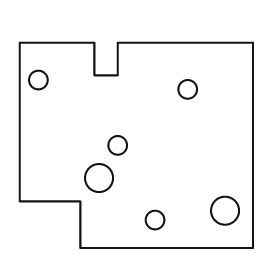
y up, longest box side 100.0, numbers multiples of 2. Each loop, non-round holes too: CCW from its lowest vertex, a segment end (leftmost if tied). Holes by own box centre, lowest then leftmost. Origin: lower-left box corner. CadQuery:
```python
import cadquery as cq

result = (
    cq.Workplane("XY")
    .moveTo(26.0, 0.0)
    .lineTo(100.0, 0.0)
    .lineTo(100.0, 88.0)
    .lineTo(42.0, 88.0)
    .lineTo(42.0, 74.0)
    .lineTo(32.0, 74.0)
    .lineTo(32.0, 88.0)
    .lineTo(0.0, 88.0)
    .lineTo(0.0, 20.0)
    .lineTo(26.0, 20.0)
    .close()
    .moveTo(58.0, 12.0)
    .circle(4.0)
    .moveTo(88.0, 16.0)
    .circle(6.0)
    .moveTo(34.0, 30.0)
    .circle(6.0)
    .moveTo(42.0, 44.0)
    .circle(4.0)
    .moveTo(72.0, 68.0)
    .circle(4.0)
    .moveTo(8.0, 72.0)
    .circle(4.0)
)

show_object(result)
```